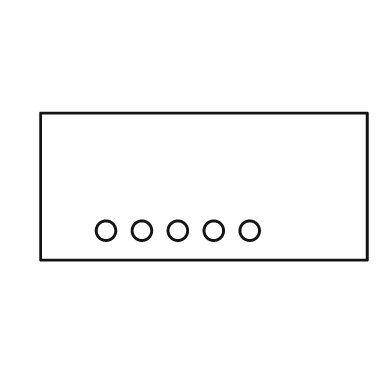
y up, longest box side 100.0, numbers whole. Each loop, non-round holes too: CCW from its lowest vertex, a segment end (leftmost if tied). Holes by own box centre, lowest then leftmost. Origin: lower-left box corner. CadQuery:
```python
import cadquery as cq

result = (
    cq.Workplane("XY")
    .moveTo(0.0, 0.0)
    .lineTo(100.0, 0.0)
    .lineTo(100.0, 45.0)
    .lineTo(0.0, 45.0)
    .close()
    .moveTo(20.0, 9.0)
    .circle(3.0)
    .moveTo(31.0, 9.0)
    .circle(3.0)
    .moveTo(42.0, 9.0)
    .circle(3.0)
    .moveTo(53.0, 9.0)
    .circle(3.0)
    .moveTo(64.0, 9.0)
    .circle(3.0)
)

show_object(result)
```